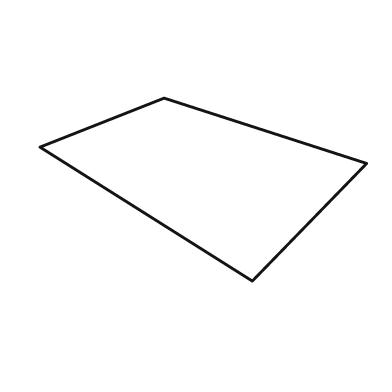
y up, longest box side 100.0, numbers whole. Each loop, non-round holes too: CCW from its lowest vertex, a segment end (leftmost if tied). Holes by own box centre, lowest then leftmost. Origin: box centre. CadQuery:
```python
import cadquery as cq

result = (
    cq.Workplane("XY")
    .moveTo(15.0, -28.0)
    .lineTo(50.0, 8.0)
    .lineTo(-12.0, 28.0)
    .lineTo(-50.0, 13.0)
    .close()
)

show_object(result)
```